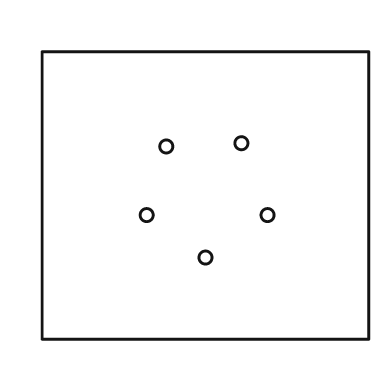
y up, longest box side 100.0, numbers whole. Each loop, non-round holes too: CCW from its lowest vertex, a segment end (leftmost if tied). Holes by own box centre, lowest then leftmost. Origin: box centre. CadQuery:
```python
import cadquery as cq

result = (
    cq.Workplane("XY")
    .moveTo(-50.0, -44.0)
    .lineTo(50.0, -44.0)
    .lineTo(50.0, 44.0)
    .lineTo(-50.0, 44.0)
    .close()
    .moveTo(0.0, -19.0)
    .circle(2.0)
    .moveTo(-18.0, -6.0)
    .circle(2.0)
    .moveTo(19.0, -6.0)
    .circle(2.0)
    .moveTo(-12.0, 15.0)
    .circle(2.0)
    .moveTo(11.0, 16.0)
    .circle(2.0)
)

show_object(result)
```